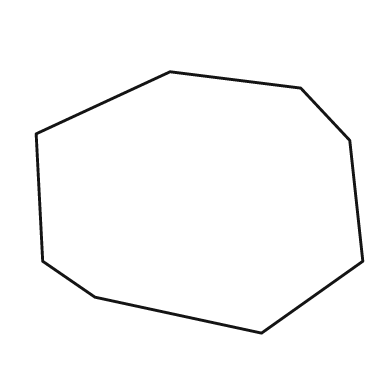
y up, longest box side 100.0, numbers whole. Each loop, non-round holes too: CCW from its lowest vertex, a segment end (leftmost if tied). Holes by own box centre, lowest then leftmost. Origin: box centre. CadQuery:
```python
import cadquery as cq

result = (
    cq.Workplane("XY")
    .moveTo(19.0, -40.0)
    .lineTo(50.0, -18.0)
    .lineTo(46.0, 19.0)
    .lineTo(31.0, 35.0)
    .lineTo(-9.0, 40.0)
    .lineTo(-50.0, 21.0)
    .lineTo(-48.0, -18.0)
    .lineTo(-32.0, -29.0)
    .close()
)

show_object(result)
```